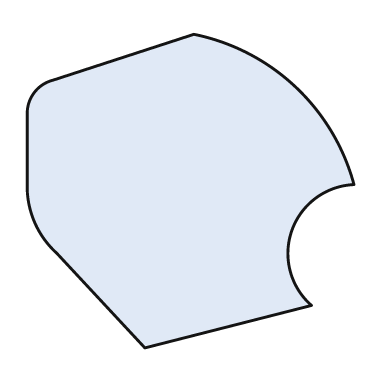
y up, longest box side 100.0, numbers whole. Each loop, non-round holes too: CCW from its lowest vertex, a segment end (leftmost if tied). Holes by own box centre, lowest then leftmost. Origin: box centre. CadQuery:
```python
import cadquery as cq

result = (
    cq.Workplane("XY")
    .moveTo(-14.0, -48.0)
    .lineTo(37.0, -35.0)
    .threePointArc((31.0, -12.0), (50.0, 2.0))
    .threePointArc((32.0, 32.0), (1.0, 48.0))
    .lineTo(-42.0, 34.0)
    .threePointArc((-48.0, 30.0), (-50.0, 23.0))
    .lineTo(-50.0, 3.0)
    .threePointArc((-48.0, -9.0), (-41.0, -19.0))
    .close()
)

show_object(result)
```